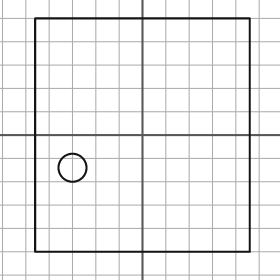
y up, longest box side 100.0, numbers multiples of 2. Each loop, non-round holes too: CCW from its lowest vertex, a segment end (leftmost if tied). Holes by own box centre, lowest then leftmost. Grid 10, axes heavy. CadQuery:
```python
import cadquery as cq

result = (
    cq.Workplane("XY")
    .moveTo(-46.0, -50.0)
    .lineTo(46.0, -50.0)
    .lineTo(46.0, 50.0)
    .lineTo(-46.0, 50.0)
    .close()
    .moveTo(-30.0, -14.0)
    .circle(6.0)
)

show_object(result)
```